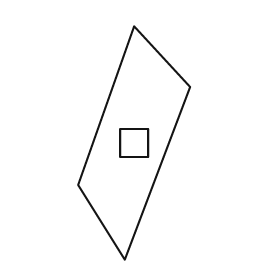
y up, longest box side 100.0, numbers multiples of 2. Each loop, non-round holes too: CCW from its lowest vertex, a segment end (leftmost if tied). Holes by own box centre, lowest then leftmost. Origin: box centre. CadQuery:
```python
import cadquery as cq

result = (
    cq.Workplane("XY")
    .moveTo(-4.0, -50.0)
    .lineTo(24.0, 24.0)
    .lineTo(0.0, 50.0)
    .lineTo(-24.0, -18.0)
    .close()
    .moveTo(-6.0, -6.0)
    .lineTo(6.0, -6.0)
    .lineTo(6.0, 6.0)
    .lineTo(-6.0, 6.0)
    .close()
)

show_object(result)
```